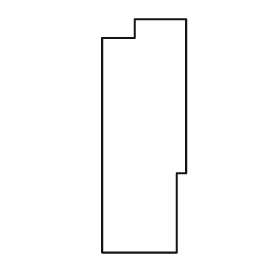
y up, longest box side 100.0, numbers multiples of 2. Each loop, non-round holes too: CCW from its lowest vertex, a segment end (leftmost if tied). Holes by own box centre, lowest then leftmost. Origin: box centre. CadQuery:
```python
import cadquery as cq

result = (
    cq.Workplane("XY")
    .moveTo(-18.0, -50.0)
    .lineTo(14.0, -50.0)
    .lineTo(14.0, -16.0)
    .lineTo(18.0, -16.0)
    .lineTo(18.0, 50.0)
    .lineTo(-4.0, 50.0)
    .lineTo(-4.0, 42.0)
    .lineTo(-18.0, 42.0)
    .close()
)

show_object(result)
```